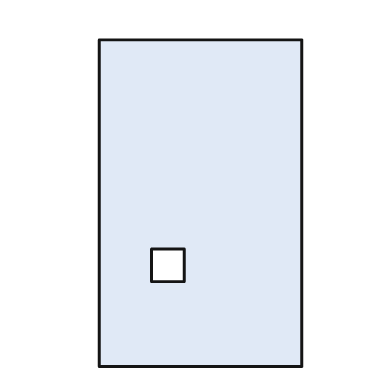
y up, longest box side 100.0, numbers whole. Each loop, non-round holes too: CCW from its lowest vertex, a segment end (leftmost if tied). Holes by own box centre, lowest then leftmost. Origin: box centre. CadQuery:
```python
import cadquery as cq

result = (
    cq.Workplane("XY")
    .moveTo(-31.0, -50.0)
    .lineTo(31.0, -50.0)
    .lineTo(31.0, 50.0)
    .lineTo(-31.0, 50.0)
    .close()
    .moveTo(-15.0, -24.0)
    .lineTo(-5.0, -24.0)
    .lineTo(-5.0, -14.0)
    .lineTo(-15.0, -14.0)
    .close()
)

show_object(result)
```